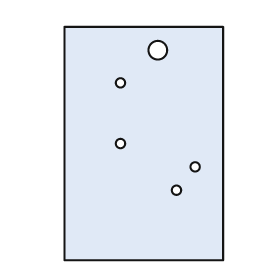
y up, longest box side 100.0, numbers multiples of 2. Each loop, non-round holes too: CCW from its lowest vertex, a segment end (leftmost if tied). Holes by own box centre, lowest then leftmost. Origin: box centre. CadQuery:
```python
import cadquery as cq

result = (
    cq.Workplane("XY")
    .moveTo(-34.0, -50.0)
    .lineTo(34.0, -50.0)
    .lineTo(34.0, 50.0)
    .lineTo(-34.0, 50.0)
    .close()
    .moveTo(14.0, -20.0)
    .circle(2.0)
    .moveTo(22.0, -10.0)
    .circle(2.0)
    .moveTo(-10.0, 0.0)
    .circle(2.0)
    .moveTo(-10.0, 26.0)
    .circle(2.0)
    .moveTo(6.0, 40.0)
    .circle(4.0)
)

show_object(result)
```